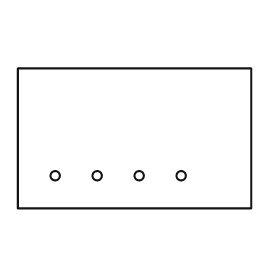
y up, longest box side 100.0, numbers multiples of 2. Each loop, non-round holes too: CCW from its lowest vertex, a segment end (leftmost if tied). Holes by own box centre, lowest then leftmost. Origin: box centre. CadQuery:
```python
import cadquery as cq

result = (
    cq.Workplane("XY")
    .moveTo(-50.0, -30.0)
    .lineTo(50.0, -30.0)
    .lineTo(50.0, 30.0)
    .lineTo(-50.0, 30.0)
    .close()
    .moveTo(-34.0, -16.0)
    .circle(2.0)
    .moveTo(-16.0, -16.0)
    .circle(2.0)
    .moveTo(2.0, -16.0)
    .circle(2.0)
    .moveTo(20.0, -16.0)
    .circle(2.0)
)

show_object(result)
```